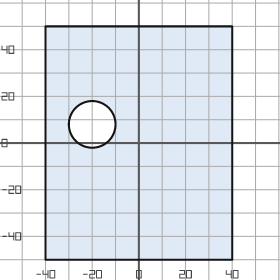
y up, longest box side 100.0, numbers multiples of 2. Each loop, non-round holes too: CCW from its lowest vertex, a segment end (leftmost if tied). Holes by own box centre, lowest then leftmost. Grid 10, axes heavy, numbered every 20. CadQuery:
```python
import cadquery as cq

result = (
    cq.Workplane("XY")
    .moveTo(-40.0, -50.0)
    .lineTo(40.0, -50.0)
    .lineTo(40.0, 50.0)
    .lineTo(-40.0, 50.0)
    .close()
    .moveTo(-20.0, 8.0)
    .circle(10.0)
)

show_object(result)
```